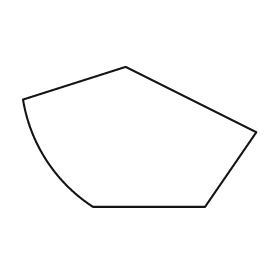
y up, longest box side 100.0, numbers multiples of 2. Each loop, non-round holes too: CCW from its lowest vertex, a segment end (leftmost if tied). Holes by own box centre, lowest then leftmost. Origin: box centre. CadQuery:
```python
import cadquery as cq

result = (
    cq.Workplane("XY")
    .moveTo(-20.0, -30.0)
    .lineTo(28.0, -30.0)
    .lineTo(50.0, 2.0)
    .lineTo(-6.0, 30.0)
    .lineTo(-50.0, 16.0)
    .threePointArc((-40.0, -10.0), (-20.0, -30.0))
    .close()
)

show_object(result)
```